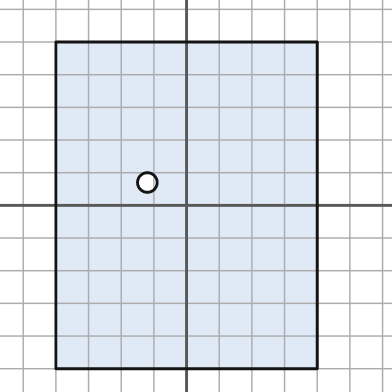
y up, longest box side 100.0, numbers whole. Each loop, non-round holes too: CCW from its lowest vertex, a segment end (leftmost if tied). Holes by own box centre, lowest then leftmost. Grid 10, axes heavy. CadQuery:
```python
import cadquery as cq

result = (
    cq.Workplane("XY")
    .moveTo(-40.0, -50.0)
    .lineTo(40.0, -50.0)
    .lineTo(40.0, 50.0)
    .lineTo(-40.0, 50.0)
    .close()
    .moveTo(-12.0, 7.0)
    .circle(3.0)
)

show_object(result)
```